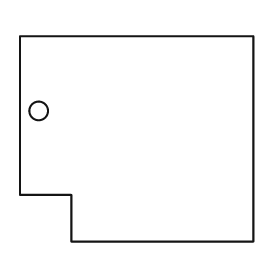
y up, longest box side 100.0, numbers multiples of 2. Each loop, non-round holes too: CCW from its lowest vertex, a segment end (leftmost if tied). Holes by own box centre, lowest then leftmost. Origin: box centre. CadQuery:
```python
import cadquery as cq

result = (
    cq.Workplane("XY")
    .moveTo(-28.0, -44.0)
    .lineTo(50.0, -44.0)
    .lineTo(50.0, 44.0)
    .lineTo(-50.0, 44.0)
    .lineTo(-50.0, -24.0)
    .lineTo(-28.0, -24.0)
    .close()
    .moveTo(-42.0, 12.0)
    .circle(4.0)
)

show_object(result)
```